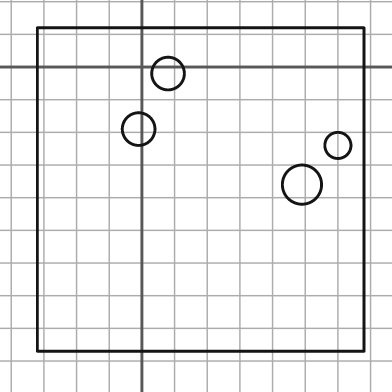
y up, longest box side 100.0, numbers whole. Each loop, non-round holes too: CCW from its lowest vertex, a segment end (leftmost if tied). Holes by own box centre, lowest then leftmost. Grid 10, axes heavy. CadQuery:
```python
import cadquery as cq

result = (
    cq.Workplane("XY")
    .moveTo(-32.0, -87.0)
    .lineTo(68.0, -87.0)
    .lineTo(68.0, 12.0)
    .lineTo(-32.0, 12.0)
    .close()
    .moveTo(49.0, -36.0)
    .circle(6.0)
    .moveTo(60.0, -24.0)
    .circle(4.0)
    .moveTo(-1.0, -19.0)
    .circle(5.0)
    .moveTo(8.0, -2.0)
    .circle(5.0)
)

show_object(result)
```